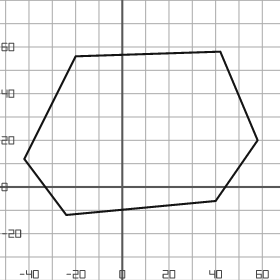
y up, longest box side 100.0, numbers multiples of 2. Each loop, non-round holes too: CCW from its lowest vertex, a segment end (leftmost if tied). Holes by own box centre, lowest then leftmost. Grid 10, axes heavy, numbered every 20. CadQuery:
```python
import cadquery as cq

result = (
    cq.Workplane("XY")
    .moveTo(-24.0, -12.0)
    .lineTo(40.0, -6.0)
    .lineTo(58.0, 20.0)
    .lineTo(42.0, 58.0)
    .lineTo(-20.0, 56.0)
    .lineTo(-42.0, 12.0)
    .close()
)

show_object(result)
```